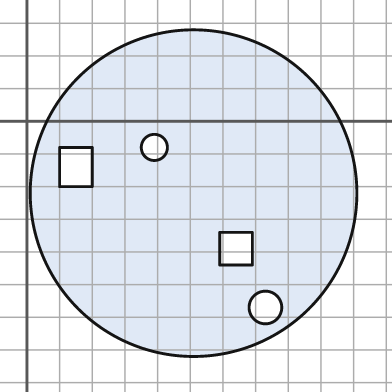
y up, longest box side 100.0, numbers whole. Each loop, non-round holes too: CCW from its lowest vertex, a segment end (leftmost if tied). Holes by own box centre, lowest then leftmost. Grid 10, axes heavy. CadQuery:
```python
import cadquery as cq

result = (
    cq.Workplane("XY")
    .moveTo(51.0, -22.0)
    .circle(50.0)
    .moveTo(73.0, -57.0)
    .circle(5.0)
    .moveTo(59.0, -44.0)
    .lineTo(69.0, -44.0)
    .lineTo(69.0, -34.0)
    .lineTo(59.0, -34.0)
    .close()
    .moveTo(10.0, -20.0)
    .lineTo(20.0, -20.0)
    .lineTo(20.0, -8.0)
    .lineTo(10.0, -8.0)
    .close()
    .moveTo(39.0, -8.0)
    .circle(4.0)
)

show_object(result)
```